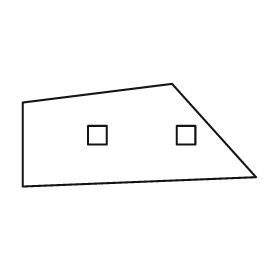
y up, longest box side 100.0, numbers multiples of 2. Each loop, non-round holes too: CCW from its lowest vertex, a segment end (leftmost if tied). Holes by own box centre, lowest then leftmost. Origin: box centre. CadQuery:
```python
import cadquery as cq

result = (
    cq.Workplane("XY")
    .moveTo(-50.0, -22.0)
    .lineTo(50.0, -18.0)
    .lineTo(14.0, 22.0)
    .lineTo(-50.0, 14.0)
    .close()
    .moveTo(-22.0, -4.0)
    .lineTo(-14.0, -4.0)
    .lineTo(-14.0, 4.0)
    .lineTo(-22.0, 4.0)
    .close()
    .moveTo(16.0, -4.0)
    .lineTo(24.0, -4.0)
    .lineTo(24.0, 4.0)
    .lineTo(16.0, 4.0)
    .close()
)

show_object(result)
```